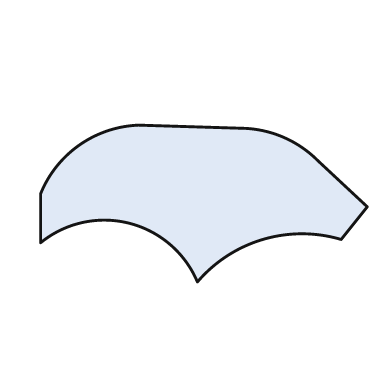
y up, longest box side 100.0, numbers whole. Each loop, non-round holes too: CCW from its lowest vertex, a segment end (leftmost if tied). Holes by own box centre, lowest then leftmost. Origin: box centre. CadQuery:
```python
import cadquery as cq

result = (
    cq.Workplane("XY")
    .moveTo(-2.0, -24.0)
    .threePointArc((18.0, -11.0), (42.0, -11.0))
    .lineTo(50.0, -1.0)
    .lineTo(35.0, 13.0)
    .threePointArc((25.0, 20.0), (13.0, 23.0))
    .lineTo(-20.0, 24.0)
    .threePointArc((-38.0, 18.0), (-50.0, 3.0))
    .lineTo(-50.0, -12.0)
    .threePointArc((-23.0, -6.0), (-2.0, -24.0))
    .close()
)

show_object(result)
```